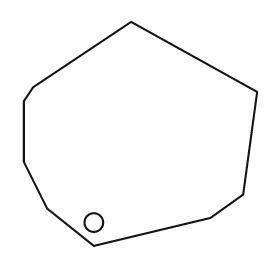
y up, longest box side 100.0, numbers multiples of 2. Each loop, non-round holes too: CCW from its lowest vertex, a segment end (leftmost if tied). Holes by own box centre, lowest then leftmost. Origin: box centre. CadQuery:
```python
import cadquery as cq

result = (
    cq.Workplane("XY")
    .moveTo(-20.0, -48.0)
    .lineTo(30.0, -36.0)
    .lineTo(44.0, -26.0)
    .lineTo(50.0, 18.0)
    .lineTo(-4.0, 48.0)
    .lineTo(-46.0, 20.0)
    .lineTo(-50.0, 14.0)
    .lineTo(-50.0, -12.0)
    .lineTo(-40.0, -32.0)
    .close()
    .moveTo(-20.0, -38.0)
    .circle(4.0)
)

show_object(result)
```